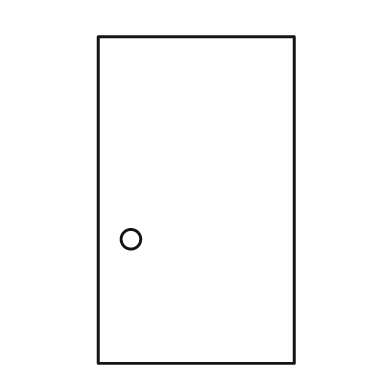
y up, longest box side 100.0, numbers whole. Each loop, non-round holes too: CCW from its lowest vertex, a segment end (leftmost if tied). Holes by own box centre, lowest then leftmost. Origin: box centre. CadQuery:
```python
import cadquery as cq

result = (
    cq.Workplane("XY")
    .moveTo(-30.0, -50.0)
    .lineTo(30.0, -50.0)
    .lineTo(30.0, 50.0)
    .lineTo(-30.0, 50.0)
    .close()
    .moveTo(-20.0, -12.0)
    .circle(3.0)
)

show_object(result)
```